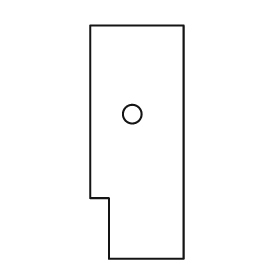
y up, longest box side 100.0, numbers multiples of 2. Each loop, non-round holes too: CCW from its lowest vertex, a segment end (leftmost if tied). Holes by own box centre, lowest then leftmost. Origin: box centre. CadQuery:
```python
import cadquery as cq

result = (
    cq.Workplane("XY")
    .moveTo(-12.0, -50.0)
    .lineTo(20.0, -50.0)
    .lineTo(20.0, 50.0)
    .lineTo(-20.0, 50.0)
    .lineTo(-20.0, -24.0)
    .lineTo(-12.0, -24.0)
    .close()
    .moveTo(-2.0, 12.0)
    .circle(4.0)
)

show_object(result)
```